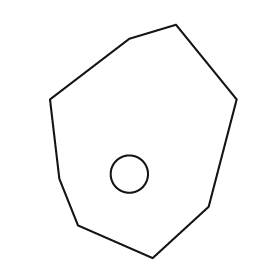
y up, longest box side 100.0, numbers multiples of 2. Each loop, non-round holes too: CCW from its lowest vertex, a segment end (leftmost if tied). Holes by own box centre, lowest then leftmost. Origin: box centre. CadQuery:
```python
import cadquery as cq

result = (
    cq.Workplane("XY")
    .moveTo(4.0, -50.0)
    .lineTo(28.0, -28.0)
    .lineTo(40.0, 18.0)
    .lineTo(14.0, 50.0)
    .lineTo(-6.0, 44.0)
    .lineTo(-40.0, 18.0)
    .lineTo(-36.0, -16.0)
    .lineTo(-28.0, -36.0)
    .close()
    .moveTo(-6.0, -14.0)
    .circle(8.0)
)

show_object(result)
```